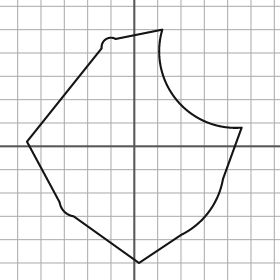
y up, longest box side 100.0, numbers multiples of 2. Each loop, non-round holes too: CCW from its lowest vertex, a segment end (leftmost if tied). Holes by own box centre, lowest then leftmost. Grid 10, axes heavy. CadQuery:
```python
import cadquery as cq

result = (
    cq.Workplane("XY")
    .moveTo(2.0, -50.0)
    .lineTo(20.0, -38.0)
    .threePointArc((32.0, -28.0), (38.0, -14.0))
    .lineTo(46.0, 8.0)
    .threePointArc((18.0, 20.0), (12.0, 50.0))
    .lineTo(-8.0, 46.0)
    .threePointArc((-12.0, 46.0), (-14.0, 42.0))
    .lineTo(-46.0, 2.0)
    .lineTo(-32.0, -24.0)
    .threePointArc((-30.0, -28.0), (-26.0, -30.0))
    .close()
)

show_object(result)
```